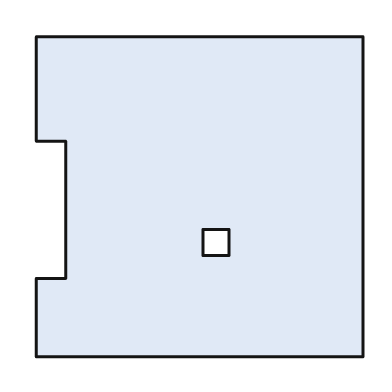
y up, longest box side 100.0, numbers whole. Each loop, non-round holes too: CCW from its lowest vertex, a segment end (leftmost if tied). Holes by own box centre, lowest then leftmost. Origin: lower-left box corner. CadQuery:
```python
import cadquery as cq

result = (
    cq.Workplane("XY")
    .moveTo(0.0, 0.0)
    .lineTo(100.0, 0.0)
    .lineTo(100.0, 98.0)
    .lineTo(0.0, 98.0)
    .lineTo(0.0, 66.0)
    .lineTo(9.0, 66.0)
    .lineTo(9.0, 24.0)
    .lineTo(0.0, 24.0)
    .close()
    .moveTo(51.0, 31.0)
    .lineTo(59.0, 31.0)
    .lineTo(59.0, 39.0)
    .lineTo(51.0, 39.0)
    .close()
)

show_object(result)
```